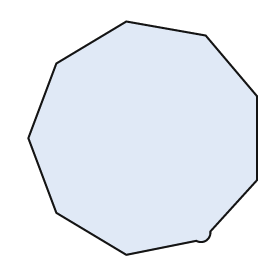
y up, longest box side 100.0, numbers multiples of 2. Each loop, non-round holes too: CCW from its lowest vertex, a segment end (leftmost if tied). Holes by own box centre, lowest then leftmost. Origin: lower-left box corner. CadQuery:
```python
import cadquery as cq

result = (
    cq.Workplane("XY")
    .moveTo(42.0, 0.0)
    .lineTo(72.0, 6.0)
    .threePointArc((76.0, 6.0), (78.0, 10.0))
    .lineTo(98.0, 32.0)
    .lineTo(98.0, 68.0)
    .lineTo(76.0, 94.0)
    .lineTo(42.0, 100.0)
    .lineTo(12.0, 82.0)
    .lineTo(0.0, 50.0)
    .lineTo(12.0, 18.0)
    .close()
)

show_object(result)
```